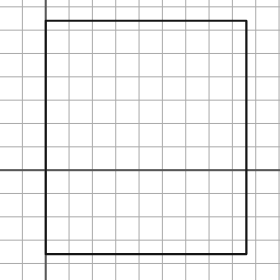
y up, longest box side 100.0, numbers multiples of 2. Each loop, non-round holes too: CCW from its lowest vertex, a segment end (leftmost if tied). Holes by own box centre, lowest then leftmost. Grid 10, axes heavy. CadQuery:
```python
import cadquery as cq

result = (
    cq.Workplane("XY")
    .moveTo(0.0, -36.0)
    .lineTo(86.0, -36.0)
    .lineTo(86.0, 64.0)
    .lineTo(0.0, 64.0)
    .close()
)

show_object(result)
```